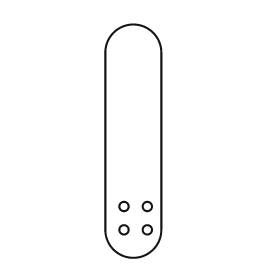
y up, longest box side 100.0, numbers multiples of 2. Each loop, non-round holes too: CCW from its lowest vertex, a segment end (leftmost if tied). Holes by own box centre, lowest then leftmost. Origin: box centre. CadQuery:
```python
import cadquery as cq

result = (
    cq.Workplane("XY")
    .moveTo(-12.0, -38.0)
    .threePointArc((0.0, -50.0), (12.0, -38.0))
    .lineTo(12.0, 38.0)
    .threePointArc((0.0, 50.0), (-12.0, 38.0))
    .close()
    .moveTo(-4.0, -38.0)
    .circle(2.0)
    .moveTo(6.0, -38.0)
    .circle(2.0)
    .moveTo(-4.0, -28.0)
    .circle(2.0)
    .moveTo(6.0, -28.0)
    .circle(2.0)
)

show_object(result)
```